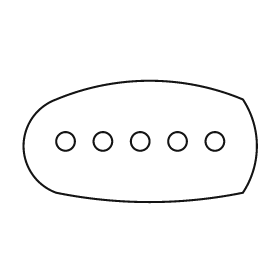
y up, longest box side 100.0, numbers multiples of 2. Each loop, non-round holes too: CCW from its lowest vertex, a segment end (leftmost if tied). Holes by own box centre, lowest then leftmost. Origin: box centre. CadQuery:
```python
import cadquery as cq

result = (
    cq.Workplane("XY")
    .moveTo(-36.0, -22.0)
    .threePointArc((4.0, -26.0), (44.0, -22.0))
    .threePointArc((50.0, -2.0), (44.0, 18.0))
    .threePointArc((4.0, 26.0), (-36.0, 18.0))
    .threePointArc((-50.0, -2.0), (-36.0, -22.0))
    .close()
    .moveTo(-32.0, 0.0)
    .circle(4.0)
    .moveTo(-16.0, 0.0)
    .circle(4.0)
    .moveTo(0.0, 0.0)
    .circle(4.0)
    .moveTo(16.0, 0.0)
    .circle(4.0)
    .moveTo(32.0, 0.0)
    .circle(4.0)
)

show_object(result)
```